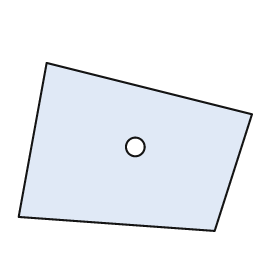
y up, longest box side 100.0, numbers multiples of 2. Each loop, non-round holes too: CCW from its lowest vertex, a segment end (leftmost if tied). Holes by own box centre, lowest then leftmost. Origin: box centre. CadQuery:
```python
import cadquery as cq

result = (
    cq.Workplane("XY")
    .moveTo(34.0, -36.0)
    .lineTo(50.0, 14.0)
    .lineTo(-38.0, 36.0)
    .lineTo(-50.0, -30.0)
    .close()
    .moveTo(0.0, 0.0)
    .circle(4.0)
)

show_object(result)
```